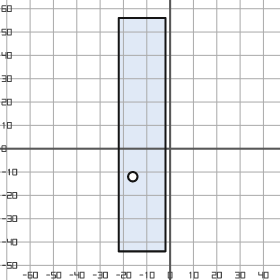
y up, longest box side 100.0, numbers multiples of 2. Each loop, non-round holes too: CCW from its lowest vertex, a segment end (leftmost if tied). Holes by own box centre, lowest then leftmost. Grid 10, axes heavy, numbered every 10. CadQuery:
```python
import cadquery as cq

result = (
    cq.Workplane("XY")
    .moveTo(-22.0, -44.0)
    .lineTo(-2.0, -44.0)
    .lineTo(-2.0, 56.0)
    .lineTo(-22.0, 56.0)
    .close()
    .moveTo(-16.0, -12.0)
    .circle(2.0)
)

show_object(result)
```